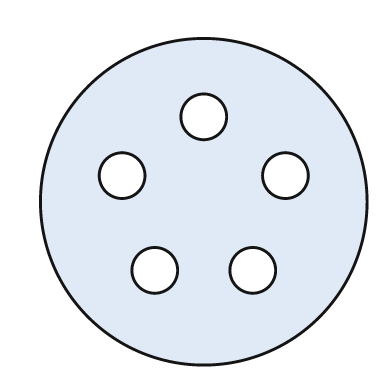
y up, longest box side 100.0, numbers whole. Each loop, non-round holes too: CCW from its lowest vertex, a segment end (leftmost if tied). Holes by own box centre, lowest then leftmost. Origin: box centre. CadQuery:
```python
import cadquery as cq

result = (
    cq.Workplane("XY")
    .moveTo(0.0, 0.0)
    .circle(50.0)
    .moveTo(-15.0, -21.0)
    .circle(7.0)
    .moveTo(15.0, -21.0)
    .circle(7.0)
    .moveTo(-25.0, 8.0)
    .circle(7.0)
    .moveTo(25.0, 8.0)
    .circle(7.0)
    .moveTo(0.0, 26.0)
    .circle(7.0)
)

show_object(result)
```